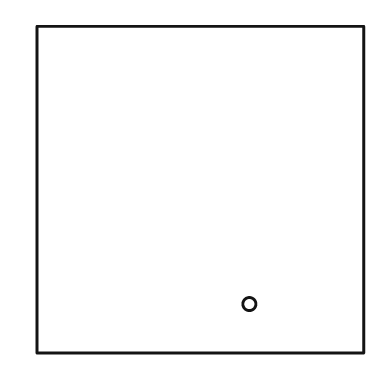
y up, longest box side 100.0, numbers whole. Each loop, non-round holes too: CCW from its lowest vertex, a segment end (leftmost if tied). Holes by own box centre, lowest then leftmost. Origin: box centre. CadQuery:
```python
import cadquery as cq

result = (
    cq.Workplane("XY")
    .moveTo(-50.0, -50.0)
    .lineTo(50.0, -50.0)
    .lineTo(50.0, 50.0)
    .lineTo(-50.0, 50.0)
    .close()
    .moveTo(15.0, -35.0)
    .circle(2.0)
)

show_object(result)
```